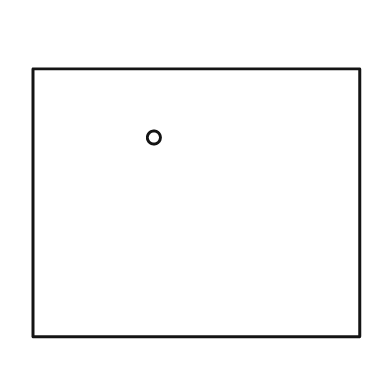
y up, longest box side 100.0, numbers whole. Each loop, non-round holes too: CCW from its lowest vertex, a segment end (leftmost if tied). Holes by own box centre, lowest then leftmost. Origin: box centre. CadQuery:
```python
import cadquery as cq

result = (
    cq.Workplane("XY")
    .moveTo(-50.0, -41.0)
    .lineTo(50.0, -41.0)
    .lineTo(50.0, 41.0)
    .lineTo(-50.0, 41.0)
    .close()
    .moveTo(-13.0, 20.0)
    .circle(2.0)
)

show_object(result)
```